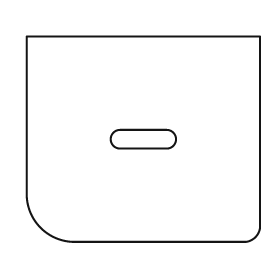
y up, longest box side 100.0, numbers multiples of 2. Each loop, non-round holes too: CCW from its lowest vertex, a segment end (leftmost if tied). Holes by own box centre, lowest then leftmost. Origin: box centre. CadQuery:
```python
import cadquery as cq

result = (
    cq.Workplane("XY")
    .moveTo(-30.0, -44.0)
    .lineTo(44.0, -44.0)
    .threePointArc((48.0, -42.0), (50.0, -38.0))
    .lineTo(50.0, 44.0)
    .lineTo(-50.0, 44.0)
    .lineTo(-50.0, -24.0)
    .threePointArc((-44.0, -38.0), (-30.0, -44.0))
    .close()
    .moveTo(-10.0, -4.0)
    .lineTo(10.0, -4.0)
    .threePointArc((14.0, 0.0), (10.0, 4.0))
    .lineTo(-10.0, 4.0)
    .threePointArc((-14.0, 0.0), (-10.0, -4.0))
    .close()
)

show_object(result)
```